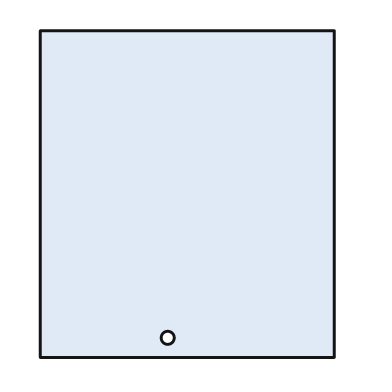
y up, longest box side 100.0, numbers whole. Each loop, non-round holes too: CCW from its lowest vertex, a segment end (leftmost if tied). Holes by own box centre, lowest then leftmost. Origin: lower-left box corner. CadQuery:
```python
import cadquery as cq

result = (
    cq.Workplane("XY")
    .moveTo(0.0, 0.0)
    .lineTo(90.0, 0.0)
    .lineTo(90.0, 100.0)
    .lineTo(0.0, 100.0)
    .close()
    .moveTo(39.0, 6.0)
    .circle(2.0)
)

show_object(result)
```